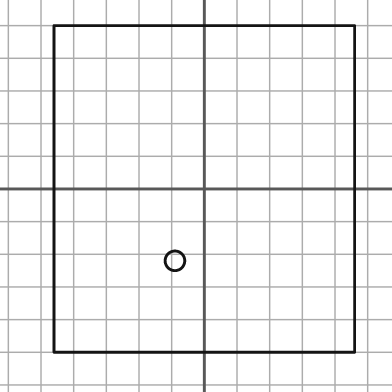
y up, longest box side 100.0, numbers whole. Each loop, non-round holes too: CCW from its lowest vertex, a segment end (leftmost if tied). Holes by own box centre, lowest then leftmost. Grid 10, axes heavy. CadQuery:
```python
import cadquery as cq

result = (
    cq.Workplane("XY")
    .moveTo(-46.0, -50.0)
    .lineTo(46.0, -50.0)
    .lineTo(46.0, 50.0)
    .lineTo(-46.0, 50.0)
    .close()
    .moveTo(-9.0, -22.0)
    .circle(3.0)
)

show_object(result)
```